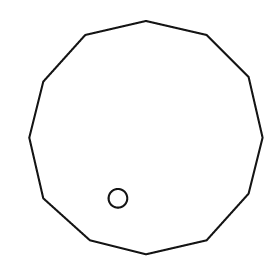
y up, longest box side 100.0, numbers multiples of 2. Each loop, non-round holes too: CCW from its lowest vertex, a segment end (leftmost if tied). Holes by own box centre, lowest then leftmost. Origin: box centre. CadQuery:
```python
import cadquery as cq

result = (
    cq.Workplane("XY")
    .moveTo(0.0, -50.0)
    .lineTo(26.0, -44.0)
    .lineTo(44.0, -24.0)
    .lineTo(50.0, 0.0)
    .lineTo(44.0, 26.0)
    .lineTo(26.0, 44.0)
    .lineTo(0.0, 50.0)
    .lineTo(-26.0, 44.0)
    .lineTo(-44.0, 24.0)
    .lineTo(-50.0, 0.0)
    .lineTo(-44.0, -26.0)
    .lineTo(-24.0, -44.0)
    .close()
    .moveTo(-12.0, -26.0)
    .circle(4.0)
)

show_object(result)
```